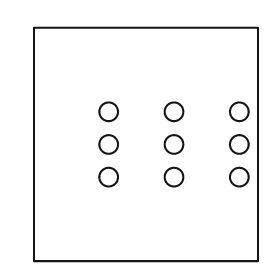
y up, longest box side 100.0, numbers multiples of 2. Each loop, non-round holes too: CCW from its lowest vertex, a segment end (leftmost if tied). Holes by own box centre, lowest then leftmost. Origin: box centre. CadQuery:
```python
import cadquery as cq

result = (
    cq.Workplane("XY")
    .moveTo(-48.0, -50.0)
    .lineTo(48.0, -50.0)
    .lineTo(48.0, 50.0)
    .lineTo(-48.0, 50.0)
    .close()
    .moveTo(-16.0, -14.0)
    .circle(4.0)
    .moveTo(12.0, -14.0)
    .circle(4.0)
    .moveTo(40.0, -14.0)
    .circle(4.0)
    .moveTo(-16.0, 0.0)
    .circle(4.0)
    .moveTo(12.0, 0.0)
    .circle(4.0)
    .moveTo(40.0, 0.0)
    .circle(4.0)
    .moveTo(-16.0, 14.0)
    .circle(4.0)
    .moveTo(12.0, 14.0)
    .circle(4.0)
    .moveTo(40.0, 14.0)
    .circle(4.0)
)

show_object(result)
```